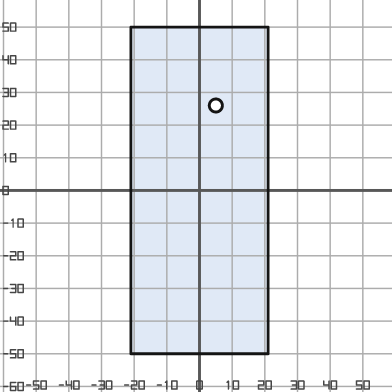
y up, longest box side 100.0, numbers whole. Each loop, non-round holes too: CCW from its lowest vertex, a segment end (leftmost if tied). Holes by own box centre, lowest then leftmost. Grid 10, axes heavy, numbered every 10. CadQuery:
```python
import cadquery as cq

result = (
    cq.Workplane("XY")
    .moveTo(-21.0, -50.0)
    .lineTo(21.0, -50.0)
    .lineTo(21.0, 50.0)
    .lineTo(-21.0, 50.0)
    .close()
    .moveTo(5.0, 26.0)
    .circle(2.0)
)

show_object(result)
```